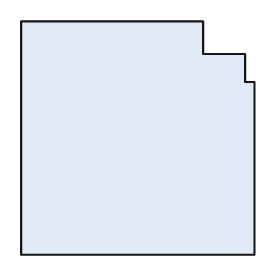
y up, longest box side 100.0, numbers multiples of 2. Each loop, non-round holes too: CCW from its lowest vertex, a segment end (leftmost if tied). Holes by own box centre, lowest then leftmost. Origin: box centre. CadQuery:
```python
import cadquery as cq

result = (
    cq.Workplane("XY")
    .moveTo(-50.0, -50.0)
    .lineTo(50.0, -50.0)
    .lineTo(50.0, 24.0)
    .lineTo(46.0, 24.0)
    .lineTo(46.0, 36.0)
    .lineTo(28.0, 36.0)
    .lineTo(28.0, 50.0)
    .lineTo(-50.0, 50.0)
    .close()
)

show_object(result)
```